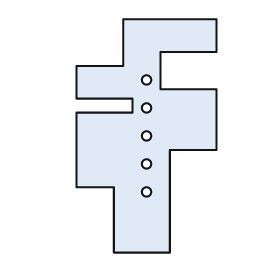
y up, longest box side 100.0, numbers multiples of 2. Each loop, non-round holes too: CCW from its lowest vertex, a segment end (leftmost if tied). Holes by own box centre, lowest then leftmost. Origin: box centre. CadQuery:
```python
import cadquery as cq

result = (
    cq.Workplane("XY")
    .moveTo(-14.0, -50.0)
    .lineTo(10.0, -50.0)
    .lineTo(10.0, -6.0)
    .lineTo(30.0, -6.0)
    .lineTo(30.0, 20.0)
    .lineTo(6.0, 20.0)
    .lineTo(6.0, 36.0)
    .lineTo(30.0, 36.0)
    .lineTo(30.0, 50.0)
    .lineTo(-10.0, 50.0)
    .lineTo(-10.0, 30.0)
    .lineTo(-30.0, 30.0)
    .lineTo(-30.0, 16.0)
    .lineTo(-6.0, 16.0)
    .lineTo(-6.0, 10.0)
    .lineTo(-30.0, 10.0)
    .lineTo(-30.0, -22.0)
    .lineTo(-14.0, -22.0)
    .close()
    .moveTo(0.0, -24.0)
    .circle(2.0)
    .moveTo(0.0, -12.0)
    .circle(2.0)
    .moveTo(0.0, 0.0)
    .circle(2.0)
    .moveTo(0.0, 12.0)
    .circle(2.0)
    .moveTo(0.0, 24.0)
    .circle(2.0)
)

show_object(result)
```